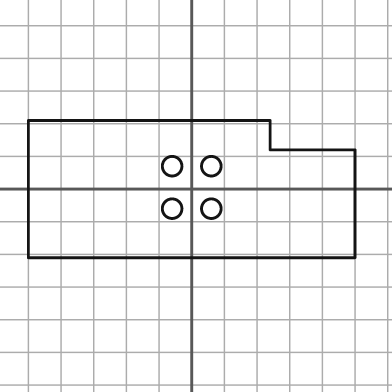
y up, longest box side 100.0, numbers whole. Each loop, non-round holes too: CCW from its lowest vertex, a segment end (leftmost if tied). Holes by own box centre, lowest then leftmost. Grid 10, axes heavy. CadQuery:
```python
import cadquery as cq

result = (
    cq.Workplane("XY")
    .moveTo(-50.0, -21.0)
    .lineTo(50.0, -21.0)
    .lineTo(50.0, 12.0)
    .lineTo(24.0, 12.0)
    .lineTo(24.0, 21.0)
    .lineTo(-50.0, 21.0)
    .close()
    .moveTo(-6.0, -6.0)
    .circle(3.0)
    .moveTo(6.0, -6.0)
    .circle(3.0)
    .moveTo(-6.0, 7.0)
    .circle(3.0)
    .moveTo(6.0, 7.0)
    .circle(3.0)
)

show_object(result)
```